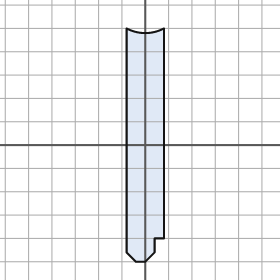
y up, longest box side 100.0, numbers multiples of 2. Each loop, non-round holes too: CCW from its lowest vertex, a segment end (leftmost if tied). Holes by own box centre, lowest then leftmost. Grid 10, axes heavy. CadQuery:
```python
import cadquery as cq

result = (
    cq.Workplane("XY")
    .moveTo(-4.0, -50.0)
    .lineTo(0.0, -50.0)
    .lineTo(4.0, -46.0)
    .lineTo(4.0, -40.0)
    .lineTo(8.0, -40.0)
    .lineTo(8.0, 50.0)
    .threePointArc((0.0, 48.0), (-8.0, 50.0))
    .lineTo(-8.0, -46.0)
    .close()
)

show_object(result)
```